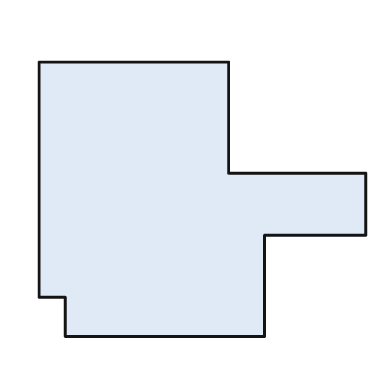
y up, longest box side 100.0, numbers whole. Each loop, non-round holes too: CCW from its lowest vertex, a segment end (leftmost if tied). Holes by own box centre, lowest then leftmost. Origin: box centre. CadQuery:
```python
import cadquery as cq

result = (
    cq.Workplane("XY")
    .moveTo(-42.0, -42.0)
    .lineTo(19.0, -42.0)
    .lineTo(19.0, -11.0)
    .lineTo(50.0, -11.0)
    .lineTo(50.0, 8.0)
    .lineTo(8.0, 8.0)
    .lineTo(8.0, 42.0)
    .lineTo(-50.0, 42.0)
    .lineTo(-50.0, -30.0)
    .lineTo(-42.0, -30.0)
    .close()
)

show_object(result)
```